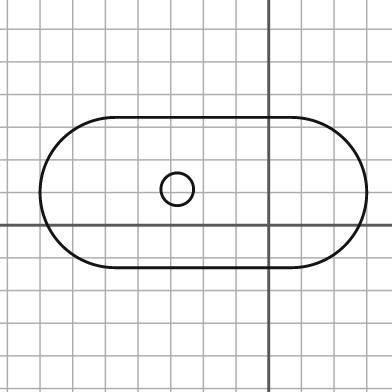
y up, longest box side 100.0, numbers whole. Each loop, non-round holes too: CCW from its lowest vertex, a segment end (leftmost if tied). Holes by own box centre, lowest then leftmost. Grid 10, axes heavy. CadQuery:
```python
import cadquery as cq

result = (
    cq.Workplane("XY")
    .moveTo(-47.0, -13.0)
    .lineTo(7.0, -13.0)
    .threePointArc((30.0, 10.0), (7.0, 33.0))
    .lineTo(-47.0, 33.0)
    .threePointArc((-70.0, 10.0), (-47.0, -13.0))
    .close()
    .moveTo(-28.0, 11.0)
    .circle(5.0)
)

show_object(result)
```